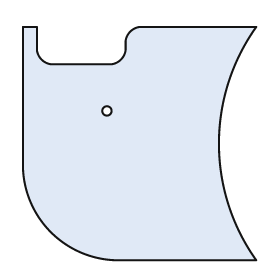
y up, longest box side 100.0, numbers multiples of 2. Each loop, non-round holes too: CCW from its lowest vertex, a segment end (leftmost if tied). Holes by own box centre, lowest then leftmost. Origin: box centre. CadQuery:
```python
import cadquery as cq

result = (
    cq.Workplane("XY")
    .moveTo(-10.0, -50.0)
    .lineTo(50.0, -50.0)
    .threePointArc((34.0, 0.0), (50.0, 50.0))
    .lineTo(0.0, 50.0)
    .threePointArc((-4.0, 48.0), (-6.0, 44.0))
    .lineTo(-6.0, 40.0)
    .threePointArc((-8.0, 36.0), (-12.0, 34.0))
    .lineTo(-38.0, 34.0)
    .threePointArc((-42.0, 36.0), (-44.0, 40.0))
    .lineTo(-44.0, 50.0)
    .lineTo(-50.0, 50.0)
    .lineTo(-50.0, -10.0)
    .threePointArc((-38.0, -38.0), (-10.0, -50.0))
    .close()
    .moveTo(-14.0, 14.0)
    .circle(2.0)
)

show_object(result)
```